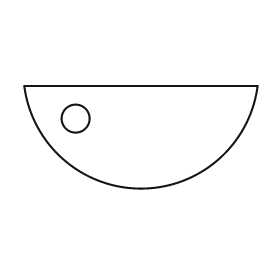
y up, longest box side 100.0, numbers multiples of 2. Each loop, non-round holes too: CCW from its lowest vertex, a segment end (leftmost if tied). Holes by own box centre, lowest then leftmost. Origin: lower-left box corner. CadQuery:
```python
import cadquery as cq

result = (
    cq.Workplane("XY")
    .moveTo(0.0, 44.0)
    .threePointArc((50.0, 0.0), (100.0, 44.0))
    .close()
    .moveTo(22.0, 30.0)
    .circle(6.0)
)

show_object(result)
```